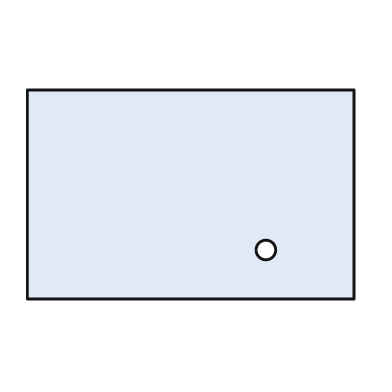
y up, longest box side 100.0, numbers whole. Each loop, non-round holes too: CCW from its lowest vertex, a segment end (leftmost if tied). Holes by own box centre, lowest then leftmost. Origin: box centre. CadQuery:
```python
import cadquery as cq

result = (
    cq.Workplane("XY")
    .moveTo(-50.0, -32.0)
    .lineTo(50.0, -32.0)
    .lineTo(50.0, 32.0)
    .lineTo(-50.0, 32.0)
    .close()
    .moveTo(23.0, -17.0)
    .circle(3.0)
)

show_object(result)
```